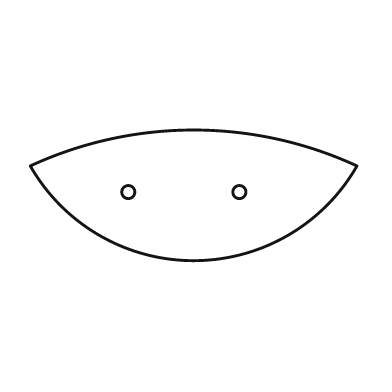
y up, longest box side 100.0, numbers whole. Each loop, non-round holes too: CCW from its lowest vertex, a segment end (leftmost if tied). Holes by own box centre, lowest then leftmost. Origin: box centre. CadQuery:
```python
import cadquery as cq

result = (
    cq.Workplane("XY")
    .moveTo(-50.0, 9.0)
    .threePointArc((0.0, -20.0), (50.0, 9.0))
    .threePointArc((0.0, 20.0), (-50.0, 9.0))
    .close()
    .moveTo(-20.0, 1.0)
    .circle(2.0)
    .moveTo(14.0, 1.0)
    .circle(2.0)
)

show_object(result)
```